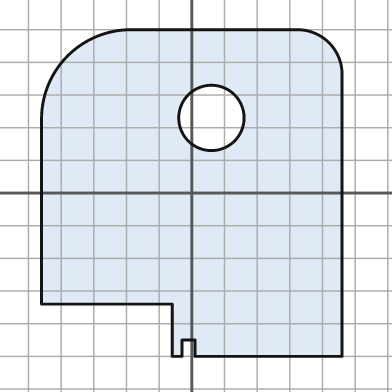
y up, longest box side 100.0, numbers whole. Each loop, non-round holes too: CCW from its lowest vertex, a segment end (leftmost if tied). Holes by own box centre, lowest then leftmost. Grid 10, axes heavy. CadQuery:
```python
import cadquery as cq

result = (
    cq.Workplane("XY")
    .moveTo(-6.0, -50.0)
    .lineTo(-3.0, -50.0)
    .lineTo(-3.0, -45.0)
    .lineTo(1.0, -45.0)
    .lineTo(1.0, -50.0)
    .lineTo(46.0, -50.0)
    .lineTo(46.0, 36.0)
    .threePointArc((42.0, 46.0), (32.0, 50.0))
    .lineTo(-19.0, 50.0)
    .threePointArc((-38.0, 42.0), (-46.0, 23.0))
    .lineTo(-46.0, -34.0)
    .lineTo(-6.0, -34.0)
    .close()
    .moveTo(6.0, 23.0)
    .circle(10.0)
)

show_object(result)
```